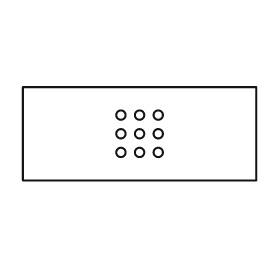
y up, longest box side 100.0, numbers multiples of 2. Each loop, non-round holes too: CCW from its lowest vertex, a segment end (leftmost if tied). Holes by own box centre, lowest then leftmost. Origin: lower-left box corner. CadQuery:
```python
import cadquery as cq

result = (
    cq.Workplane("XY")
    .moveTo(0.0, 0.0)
    .lineTo(100.0, 0.0)
    .lineTo(100.0, 40.0)
    .lineTo(0.0, 40.0)
    .close()
    .moveTo(42.0, 12.0)
    .circle(2.0)
    .moveTo(50.0, 12.0)
    .circle(2.0)
    .moveTo(58.0, 12.0)
    .circle(2.0)
    .moveTo(42.0, 20.0)
    .circle(2.0)
    .moveTo(50.0, 20.0)
    .circle(2.0)
    .moveTo(58.0, 20.0)
    .circle(2.0)
    .moveTo(42.0, 28.0)
    .circle(2.0)
    .moveTo(50.0, 28.0)
    .circle(2.0)
    .moveTo(58.0, 28.0)
    .circle(2.0)
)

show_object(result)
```